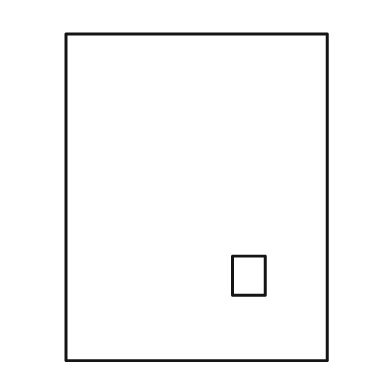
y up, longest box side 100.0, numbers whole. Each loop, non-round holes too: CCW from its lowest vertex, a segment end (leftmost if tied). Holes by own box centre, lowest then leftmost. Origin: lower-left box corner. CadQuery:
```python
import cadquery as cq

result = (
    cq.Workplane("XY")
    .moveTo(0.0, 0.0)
    .lineTo(80.0, 0.0)
    .lineTo(80.0, 100.0)
    .lineTo(0.0, 100.0)
    .close()
    .moveTo(51.0, 20.0)
    .lineTo(61.0, 20.0)
    .lineTo(61.0, 32.0)
    .lineTo(51.0, 32.0)
    .close()
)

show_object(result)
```